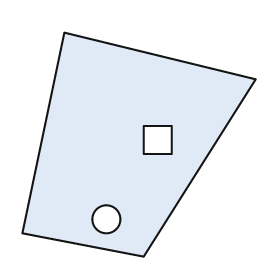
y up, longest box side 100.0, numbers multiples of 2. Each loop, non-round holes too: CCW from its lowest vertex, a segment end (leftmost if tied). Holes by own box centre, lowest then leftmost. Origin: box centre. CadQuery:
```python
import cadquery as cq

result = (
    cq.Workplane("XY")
    .moveTo(2.0, -48.0)
    .lineTo(50.0, 28.0)
    .lineTo(-32.0, 48.0)
    .lineTo(-50.0, -38.0)
    .close()
    .moveTo(-14.0, -32.0)
    .circle(6.0)
    .moveTo(2.0, -4.0)
    .lineTo(14.0, -4.0)
    .lineTo(14.0, 8.0)
    .lineTo(2.0, 8.0)
    .close()
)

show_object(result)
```